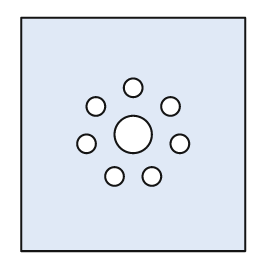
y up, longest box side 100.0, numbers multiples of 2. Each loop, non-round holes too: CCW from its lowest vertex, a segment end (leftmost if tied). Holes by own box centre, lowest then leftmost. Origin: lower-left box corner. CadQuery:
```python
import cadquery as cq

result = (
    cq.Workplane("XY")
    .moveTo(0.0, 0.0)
    .lineTo(96.0, 0.0)
    .lineTo(96.0, 100.0)
    .lineTo(0.0, 100.0)
    .close()
    .moveTo(40.0, 32.0)
    .circle(4.0)
    .moveTo(56.0, 32.0)
    .circle(4.0)
    .moveTo(28.0, 46.0)
    .circle(4.0)
    .moveTo(68.0, 46.0)
    .circle(4.0)
    .moveTo(48.0, 50.0)
    .circle(8.0)
    .moveTo(32.0, 62.0)
    .circle(4.0)
    .moveTo(64.0, 62.0)
    .circle(4.0)
    .moveTo(48.0, 70.0)
    .circle(4.0)
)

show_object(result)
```